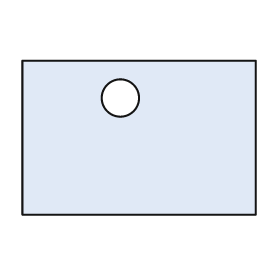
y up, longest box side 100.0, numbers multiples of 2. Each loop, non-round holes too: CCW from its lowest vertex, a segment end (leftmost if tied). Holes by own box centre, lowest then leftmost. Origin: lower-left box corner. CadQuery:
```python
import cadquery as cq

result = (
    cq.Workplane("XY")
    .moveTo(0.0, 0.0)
    .lineTo(100.0, 0.0)
    .lineTo(100.0, 66.0)
    .lineTo(0.0, 66.0)
    .close()
    .moveTo(42.0, 50.0)
    .circle(8.0)
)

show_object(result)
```